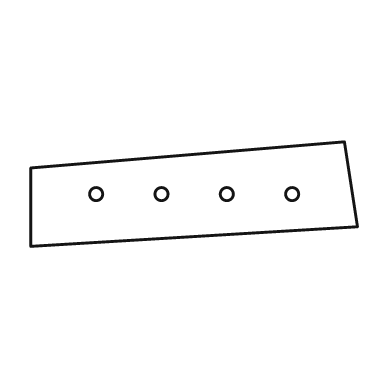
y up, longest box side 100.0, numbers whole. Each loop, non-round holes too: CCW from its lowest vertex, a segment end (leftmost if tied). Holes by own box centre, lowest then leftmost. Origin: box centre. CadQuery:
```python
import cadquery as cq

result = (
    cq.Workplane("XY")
    .moveTo(-50.0, -16.0)
    .lineTo(50.0, -10.0)
    .lineTo(46.0, 16.0)
    .lineTo(-50.0, 8.0)
    .close()
    .moveTo(-30.0, 0.0)
    .circle(2.0)
    .moveTo(-10.0, 0.0)
    .circle(2.0)
    .moveTo(10.0, 0.0)
    .circle(2.0)
    .moveTo(30.0, 0.0)
    .circle(2.0)
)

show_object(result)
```